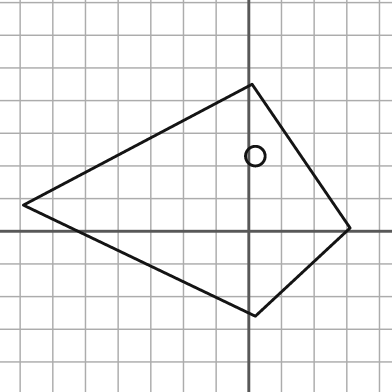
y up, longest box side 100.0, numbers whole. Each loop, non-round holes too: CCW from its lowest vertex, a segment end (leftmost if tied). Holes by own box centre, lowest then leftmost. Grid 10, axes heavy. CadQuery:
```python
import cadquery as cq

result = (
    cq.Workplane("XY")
    .moveTo(2.0, -26.0)
    .lineTo(31.0, 1.0)
    .lineTo(1.0, 45.0)
    .lineTo(-69.0, 8.0)
    .close()
    .moveTo(2.0, 23.0)
    .circle(3.0)
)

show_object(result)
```